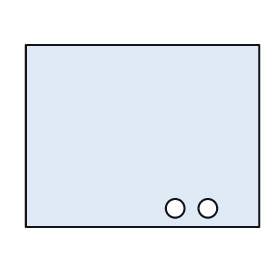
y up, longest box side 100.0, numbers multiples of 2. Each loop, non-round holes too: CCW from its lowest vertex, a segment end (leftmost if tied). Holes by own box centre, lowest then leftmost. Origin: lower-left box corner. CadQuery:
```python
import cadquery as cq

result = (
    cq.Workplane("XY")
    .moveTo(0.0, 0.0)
    .lineTo(100.0, 0.0)
    .lineTo(100.0, 78.0)
    .lineTo(0.0, 78.0)
    .close()
    .moveTo(64.0, 8.0)
    .circle(4.0)
    .moveTo(78.0, 8.0)
    .circle(4.0)
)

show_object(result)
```